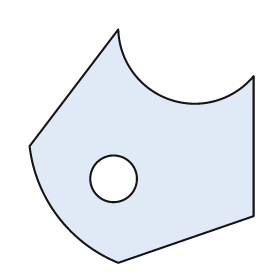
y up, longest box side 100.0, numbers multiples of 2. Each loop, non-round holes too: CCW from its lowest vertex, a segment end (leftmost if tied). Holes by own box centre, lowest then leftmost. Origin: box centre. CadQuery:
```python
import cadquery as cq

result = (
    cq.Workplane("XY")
    .moveTo(-10.0, -50.0)
    .lineTo(48.0, -30.0)
    .lineTo(48.0, 30.0)
    .threePointArc((12.0, 20.0), (-10.0, 50.0))
    .lineTo(-48.0, 0.0)
    .threePointArc((-36.0, -30.0), (-10.0, -50.0))
    .close()
    .moveTo(-12.0, -14.0)
    .circle(10.0)
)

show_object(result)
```